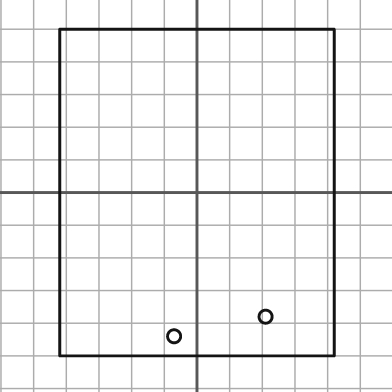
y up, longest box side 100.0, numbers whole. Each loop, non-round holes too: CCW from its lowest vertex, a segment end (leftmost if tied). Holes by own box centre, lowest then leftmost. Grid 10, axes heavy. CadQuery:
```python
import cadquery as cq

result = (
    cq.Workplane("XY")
    .moveTo(-42.0, -50.0)
    .lineTo(42.0, -50.0)
    .lineTo(42.0, 50.0)
    .lineTo(-42.0, 50.0)
    .close()
    .moveTo(-7.0, -44.0)
    .circle(2.0)
    .moveTo(21.0, -38.0)
    .circle(2.0)
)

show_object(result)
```